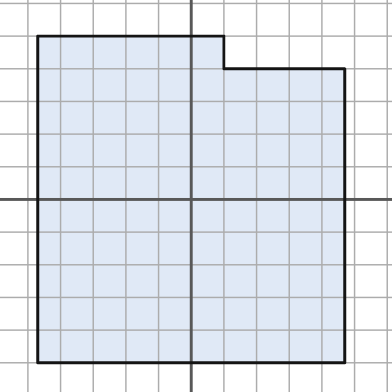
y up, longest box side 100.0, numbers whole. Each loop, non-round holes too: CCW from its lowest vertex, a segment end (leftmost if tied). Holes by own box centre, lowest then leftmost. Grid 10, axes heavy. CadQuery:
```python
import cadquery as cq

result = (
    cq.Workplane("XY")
    .moveTo(-47.0, -50.0)
    .lineTo(47.0, -50.0)
    .lineTo(47.0, 40.0)
    .lineTo(10.0, 40.0)
    .lineTo(10.0, 50.0)
    .lineTo(-47.0, 50.0)
    .close()
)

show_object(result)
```